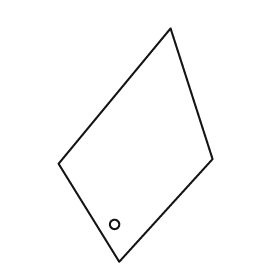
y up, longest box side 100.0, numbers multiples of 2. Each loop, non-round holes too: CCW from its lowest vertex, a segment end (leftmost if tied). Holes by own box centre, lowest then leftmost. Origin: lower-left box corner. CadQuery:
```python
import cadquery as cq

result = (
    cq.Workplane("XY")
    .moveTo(26.0, 0.0)
    .lineTo(66.0, 44.0)
    .lineTo(48.0, 100.0)
    .lineTo(0.0, 42.0)
    .close()
    .moveTo(24.0, 16.0)
    .circle(2.0)
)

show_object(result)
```